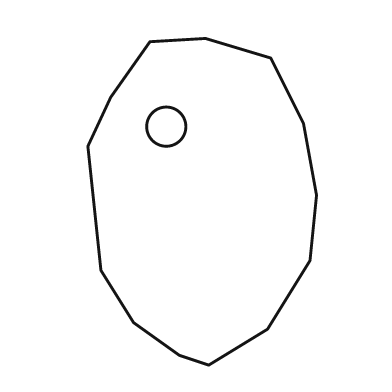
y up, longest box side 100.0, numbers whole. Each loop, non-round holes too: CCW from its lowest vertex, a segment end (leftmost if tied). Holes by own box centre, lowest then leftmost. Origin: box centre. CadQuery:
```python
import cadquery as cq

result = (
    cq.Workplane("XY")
    .moveTo(2.0, -50.0)
    .lineTo(20.0, -39.0)
    .lineTo(33.0, -18.0)
    .lineTo(35.0, 2.0)
    .lineTo(31.0, 24.0)
    .lineTo(21.0, 44.0)
    .lineTo(1.0, 50.0)
    .lineTo(-16.0, 49.0)
    .lineTo(-28.0, 32.0)
    .lineTo(-35.0, 17.0)
    .lineTo(-31.0, -21.0)
    .lineTo(-21.0, -37.0)
    .lineTo(-7.0, -47.0)
    .close()
    .moveTo(-11.0, 23.0)
    .circle(6.0)
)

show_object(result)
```